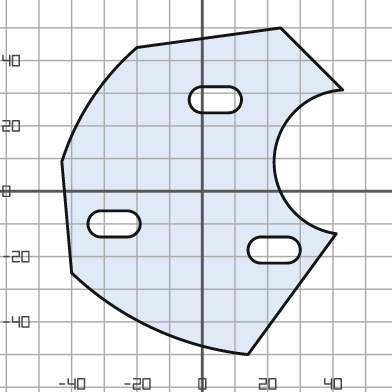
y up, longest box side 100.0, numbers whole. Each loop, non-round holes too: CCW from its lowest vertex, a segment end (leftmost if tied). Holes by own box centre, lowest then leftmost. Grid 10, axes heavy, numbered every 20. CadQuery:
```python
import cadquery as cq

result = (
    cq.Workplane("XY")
    .moveTo(14.0, -50.0)
    .lineTo(41.0, -13.0)
    .threePointArc((22.0, 10.0), (43.0, 31.0))
    .lineTo(24.0, 50.0)
    .lineTo(-20.0, 44.0)
    .threePointArc((-34.0, 28.0), (-43.0, 9.0))
    .lineTo(-40.0, -25.0)
    .threePointArc((-15.0, -42.0), (14.0, -50.0))
    .close()
    .moveTo(18.0, -22.0)
    .lineTo(26.0, -22.0)
    .threePointArc((30.0, -18.0), (26.0, -14.0))
    .lineTo(18.0, -14.0)
    .threePointArc((14.0, -18.0), (18.0, -22.0))
    .close()
    .moveTo(-31.0, -14.0)
    .lineTo(-23.0, -14.0)
    .threePointArc((-19.0, -10.0), (-23.0, -6.0))
    .lineTo(-31.0, -6.0)
    .threePointArc((-35.0, -10.0), (-31.0, -14.0))
    .close()
    .moveTo(0.0, 24.0)
    .lineTo(8.0, 24.0)
    .threePointArc((12.0, 28.0), (8.0, 32.0))
    .lineTo(0.0, 32.0)
    .threePointArc((-4.0, 28.0), (0.0, 24.0))
    .close()
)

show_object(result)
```